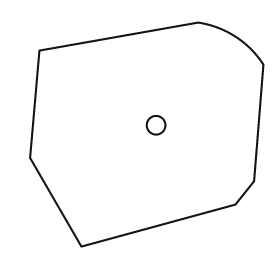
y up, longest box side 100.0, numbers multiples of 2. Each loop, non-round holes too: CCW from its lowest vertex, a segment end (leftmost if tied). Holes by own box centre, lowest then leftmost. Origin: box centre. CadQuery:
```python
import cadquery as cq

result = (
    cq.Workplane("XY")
    .moveTo(-28.0, -48.0)
    .lineTo(38.0, -30.0)
    .lineTo(46.0, -20.0)
    .lineTo(50.0, 30.0)
    .threePointArc((38.0, 42.0), (22.0, 48.0))
    .lineTo(-46.0, 36.0)
    .lineTo(-50.0, -10.0)
    .close()
    .moveTo(4.0, 4.0)
    .circle(4.0)
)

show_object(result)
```